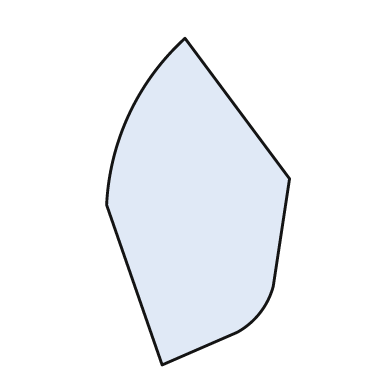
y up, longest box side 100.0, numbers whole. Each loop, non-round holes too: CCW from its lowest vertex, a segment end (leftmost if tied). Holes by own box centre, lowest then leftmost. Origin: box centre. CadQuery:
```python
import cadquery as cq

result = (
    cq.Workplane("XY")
    .moveTo(-11.0, -50.0)
    .lineTo(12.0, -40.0)
    .threePointArc((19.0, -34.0), (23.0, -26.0))
    .lineTo(28.0, 7.0)
    .lineTo(-4.0, 50.0)
    .threePointArc((-21.0, 27.0), (-28.0, -1.0))
    .close()
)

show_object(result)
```